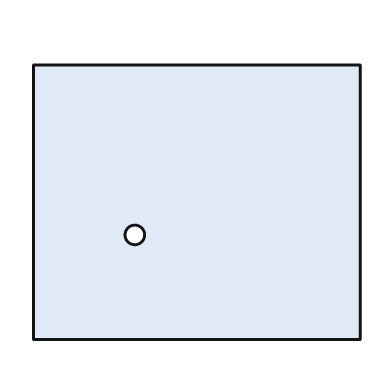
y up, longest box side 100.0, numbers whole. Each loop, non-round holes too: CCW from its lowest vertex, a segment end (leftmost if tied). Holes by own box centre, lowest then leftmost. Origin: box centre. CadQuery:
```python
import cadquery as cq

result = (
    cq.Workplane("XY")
    .moveTo(-50.0, -42.0)
    .lineTo(50.0, -42.0)
    .lineTo(50.0, 42.0)
    .lineTo(-50.0, 42.0)
    .close()
    .moveTo(-19.0, -10.0)
    .circle(3.0)
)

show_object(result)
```